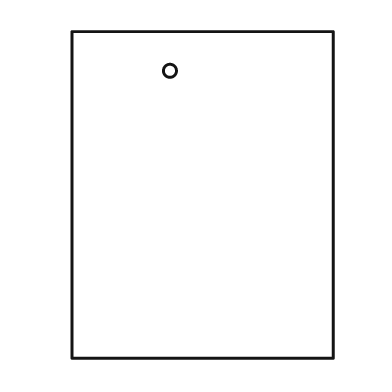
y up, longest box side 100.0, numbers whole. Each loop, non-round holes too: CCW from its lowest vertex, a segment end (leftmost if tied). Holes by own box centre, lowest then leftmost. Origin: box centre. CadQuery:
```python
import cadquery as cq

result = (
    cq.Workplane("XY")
    .moveTo(-40.0, -50.0)
    .lineTo(40.0, -50.0)
    .lineTo(40.0, 50.0)
    .lineTo(-40.0, 50.0)
    .close()
    .moveTo(-10.0, 38.0)
    .circle(2.0)
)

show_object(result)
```